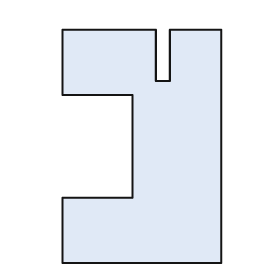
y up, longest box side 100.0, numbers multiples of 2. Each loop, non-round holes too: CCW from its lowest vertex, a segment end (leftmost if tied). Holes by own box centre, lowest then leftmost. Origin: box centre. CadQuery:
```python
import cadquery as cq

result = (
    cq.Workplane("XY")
    .moveTo(-34.0, -50.0)
    .lineTo(34.0, -50.0)
    .lineTo(34.0, 50.0)
    .lineTo(12.0, 50.0)
    .lineTo(12.0, 28.0)
    .lineTo(6.0, 28.0)
    .lineTo(6.0, 50.0)
    .lineTo(-34.0, 50.0)
    .lineTo(-34.0, 22.0)
    .lineTo(-4.0, 22.0)
    .lineTo(-4.0, -22.0)
    .lineTo(-34.0, -22.0)
    .close()
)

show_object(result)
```